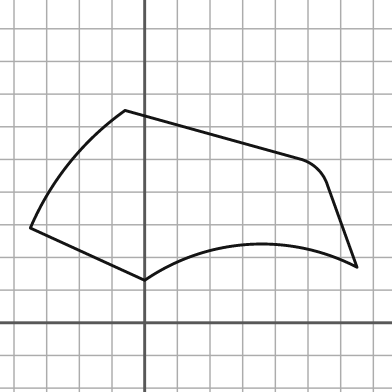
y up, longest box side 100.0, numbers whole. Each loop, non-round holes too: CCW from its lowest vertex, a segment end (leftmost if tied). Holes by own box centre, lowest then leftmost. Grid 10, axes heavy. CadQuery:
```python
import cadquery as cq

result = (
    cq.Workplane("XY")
    .moveTo(0.0, 13.0)
    .threePointArc((32.0, 24.0), (65.0, 17.0))
    .lineTo(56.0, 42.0)
    .threePointArc((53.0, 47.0), (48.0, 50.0))
    .lineTo(-6.0, 65.0)
    .threePointArc((-23.0, 49.0), (-35.0, 29.0))
    .close()
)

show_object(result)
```